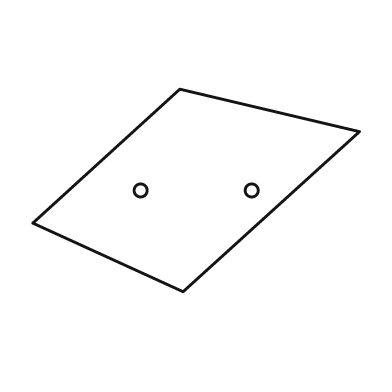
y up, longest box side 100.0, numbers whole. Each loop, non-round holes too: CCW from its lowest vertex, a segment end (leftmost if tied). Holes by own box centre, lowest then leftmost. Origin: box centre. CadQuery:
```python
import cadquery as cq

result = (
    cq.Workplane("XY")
    .moveTo(-4.0, -31.0)
    .lineTo(50.0, 18.0)
    .lineTo(-5.0, 31.0)
    .lineTo(-50.0, -10.0)
    .close()
    .moveTo(-17.0, 0.0)
    .circle(2.0)
    .moveTo(17.0, 0.0)
    .circle(2.0)
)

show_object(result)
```